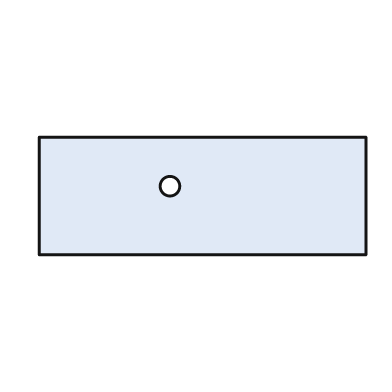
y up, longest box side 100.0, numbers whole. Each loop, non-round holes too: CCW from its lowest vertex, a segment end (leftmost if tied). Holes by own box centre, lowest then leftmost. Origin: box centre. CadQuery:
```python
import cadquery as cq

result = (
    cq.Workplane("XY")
    .moveTo(-50.0, -18.0)
    .lineTo(50.0, -18.0)
    .lineTo(50.0, 18.0)
    .lineTo(-50.0, 18.0)
    .close()
    .moveTo(-10.0, 3.0)
    .circle(3.0)
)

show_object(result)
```